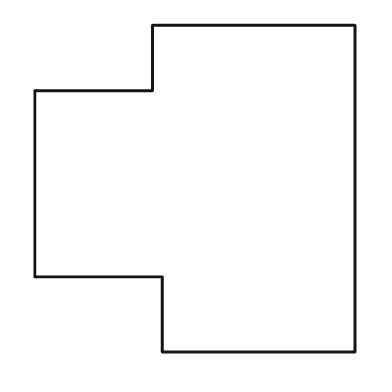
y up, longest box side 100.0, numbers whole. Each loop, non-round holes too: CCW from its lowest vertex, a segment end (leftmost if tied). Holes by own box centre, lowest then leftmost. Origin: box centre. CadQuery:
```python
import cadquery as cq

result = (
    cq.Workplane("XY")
    .moveTo(-10.0, -50.0)
    .lineTo(49.0, -50.0)
    .lineTo(49.0, 50.0)
    .lineTo(-13.0, 50.0)
    .lineTo(-13.0, 30.0)
    .lineTo(-49.0, 30.0)
    .lineTo(-49.0, -27.0)
    .lineTo(-10.0, -27.0)
    .close()
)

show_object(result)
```